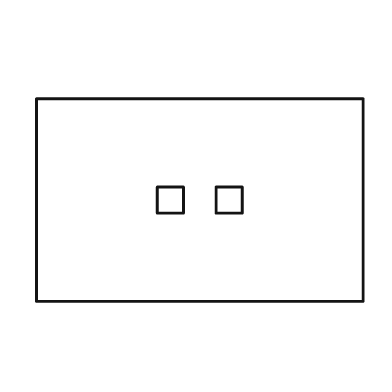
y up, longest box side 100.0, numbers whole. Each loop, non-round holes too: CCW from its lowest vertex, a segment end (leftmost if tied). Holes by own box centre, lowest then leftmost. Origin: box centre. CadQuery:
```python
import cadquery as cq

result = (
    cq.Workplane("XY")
    .moveTo(-50.0, -31.0)
    .lineTo(50.0, -31.0)
    .lineTo(50.0, 31.0)
    .lineTo(-50.0, 31.0)
    .close()
    .moveTo(-13.0, -4.0)
    .lineTo(-5.0, -4.0)
    .lineTo(-5.0, 4.0)
    .lineTo(-13.0, 4.0)
    .close()
    .moveTo(5.0, -4.0)
    .lineTo(13.0, -4.0)
    .lineTo(13.0, 4.0)
    .lineTo(5.0, 4.0)
    .close()
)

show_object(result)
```